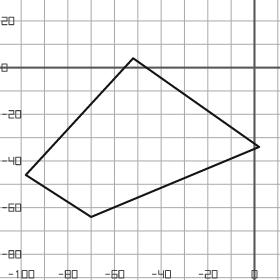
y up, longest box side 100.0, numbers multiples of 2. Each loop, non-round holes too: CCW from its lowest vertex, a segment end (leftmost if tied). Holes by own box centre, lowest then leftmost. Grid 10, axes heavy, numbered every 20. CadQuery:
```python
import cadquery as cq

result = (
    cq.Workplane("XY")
    .moveTo(-70.0, -64.0)
    .lineTo(2.0, -34.0)
    .lineTo(-52.0, 4.0)
    .lineTo(-98.0, -46.0)
    .close()
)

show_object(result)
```